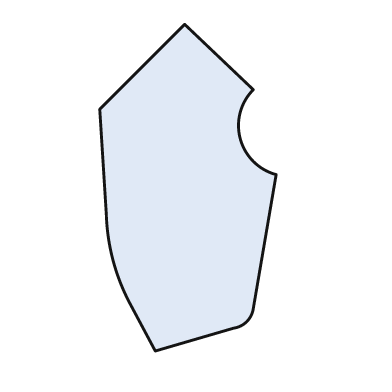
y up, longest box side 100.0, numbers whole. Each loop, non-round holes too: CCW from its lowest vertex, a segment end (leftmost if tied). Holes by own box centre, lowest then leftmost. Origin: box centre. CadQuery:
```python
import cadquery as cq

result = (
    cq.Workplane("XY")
    .moveTo(-10.0, -50.0)
    .lineTo(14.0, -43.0)
    .threePointArc((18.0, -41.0), (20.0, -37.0))
    .lineTo(27.0, 4.0)
    .threePointArc((16.0, 15.0), (20.0, 30.0))
    .lineTo(-1.0, 50.0)
    .lineTo(-27.0, 24.0)
    .lineTo(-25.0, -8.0)
    .threePointArc((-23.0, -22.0), (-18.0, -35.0))
    .close()
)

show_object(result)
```